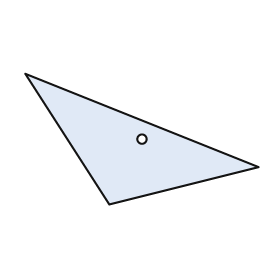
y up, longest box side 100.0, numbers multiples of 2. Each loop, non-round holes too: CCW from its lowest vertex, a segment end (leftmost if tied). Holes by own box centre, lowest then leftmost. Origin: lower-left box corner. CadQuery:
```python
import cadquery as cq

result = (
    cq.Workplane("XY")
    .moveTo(36.0, 0.0)
    .lineTo(100.0, 16.0)
    .lineTo(0.0, 56.0)
    .close()
    .moveTo(50.0, 28.0)
    .circle(2.0)
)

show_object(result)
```